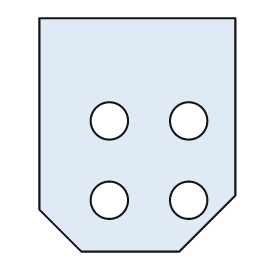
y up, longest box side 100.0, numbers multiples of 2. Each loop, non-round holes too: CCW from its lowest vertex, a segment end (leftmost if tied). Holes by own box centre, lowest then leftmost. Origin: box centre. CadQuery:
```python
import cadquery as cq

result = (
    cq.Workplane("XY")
    .moveTo(-24.0, -50.0)
    .lineTo(18.0, -50.0)
    .lineTo(42.0, -26.0)
    .lineTo(42.0, 50.0)
    .lineTo(-42.0, 50.0)
    .lineTo(-42.0, -32.0)
    .close()
    .moveTo(-12.0, -28.0)
    .circle(8.0)
    .moveTo(22.0, -28.0)
    .circle(8.0)
    .moveTo(-12.0, 6.0)
    .circle(8.0)
    .moveTo(22.0, 6.0)
    .circle(8.0)
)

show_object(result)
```